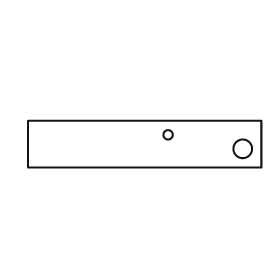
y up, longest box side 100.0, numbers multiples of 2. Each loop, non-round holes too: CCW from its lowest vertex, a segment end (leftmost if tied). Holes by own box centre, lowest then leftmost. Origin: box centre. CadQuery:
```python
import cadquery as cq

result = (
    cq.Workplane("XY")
    .moveTo(-50.0, -10.0)
    .lineTo(50.0, -10.0)
    .lineTo(50.0, 10.0)
    .lineTo(-50.0, 10.0)
    .close()
    .moveTo(42.0, -2.0)
    .circle(4.0)
    .moveTo(10.0, 4.0)
    .circle(2.0)
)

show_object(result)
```